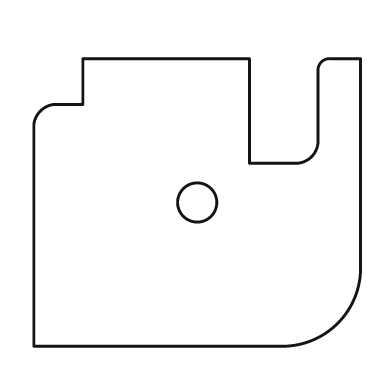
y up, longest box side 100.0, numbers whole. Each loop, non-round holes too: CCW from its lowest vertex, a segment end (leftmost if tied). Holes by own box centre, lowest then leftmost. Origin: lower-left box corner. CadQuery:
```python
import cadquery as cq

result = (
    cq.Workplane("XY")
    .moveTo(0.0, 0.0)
    .lineTo(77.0, 0.0)
    .threePointArc((93.0, 7.0), (100.0, 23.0))
    .lineTo(100.0, 88.0)
    .lineTo(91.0, 88.0)
    .threePointArc((88.0, 87.0), (87.0, 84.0))
    .lineTo(87.0, 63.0)
    .threePointArc((85.0, 58.0), (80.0, 56.0))
    .lineTo(66.0, 56.0)
    .lineTo(66.0, 88.0)
    .lineTo(15.0, 88.0)
    .lineTo(15.0, 74.0)
    .lineTo(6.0, 74.0)
    .threePointArc((2.0, 72.0), (0.0, 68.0))
    .close()
    .moveTo(50.0, 44.0)
    .circle(6.0)
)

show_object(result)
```